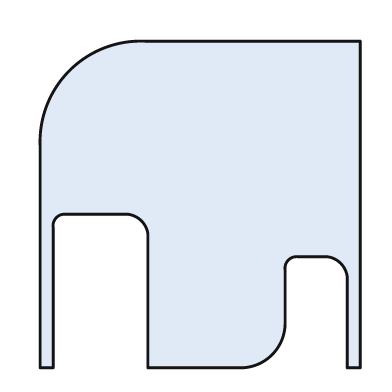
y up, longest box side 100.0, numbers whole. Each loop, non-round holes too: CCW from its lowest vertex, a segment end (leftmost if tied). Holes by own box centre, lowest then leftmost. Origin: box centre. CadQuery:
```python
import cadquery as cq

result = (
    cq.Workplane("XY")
    .moveTo(-49.0, -50.0)
    .lineTo(-45.0, -50.0)
    .lineTo(-45.0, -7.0)
    .threePointArc((-44.0, -4.0), (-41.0, -3.0))
    .lineTo(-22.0, -3.0)
    .threePointArc((-18.0, -5.0), (-16.0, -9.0))
    .lineTo(-16.0, -50.0)
    .lineTo(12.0, -50.0)
    .threePointArc((22.0, -46.0), (26.0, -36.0))
    .lineTo(26.0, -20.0)
    .threePointArc((27.0, -17.0), (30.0, -16.0))
    .lineTo(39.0, -16.0)
    .threePointArc((43.0, -18.0), (45.0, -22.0))
    .lineTo(45.0, -50.0)
    .lineTo(49.0, -50.0)
    .lineTo(49.0, 50.0)
    .lineTo(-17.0, 50.0)
    .threePointArc((-40.0, 41.0), (-49.0, 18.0))
    .close()
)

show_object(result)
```